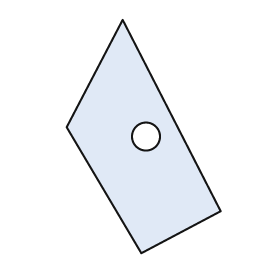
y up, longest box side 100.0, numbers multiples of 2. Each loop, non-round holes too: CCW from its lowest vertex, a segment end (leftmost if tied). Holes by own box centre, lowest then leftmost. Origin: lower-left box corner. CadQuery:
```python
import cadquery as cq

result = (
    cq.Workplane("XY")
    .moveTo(32.0, 0.0)
    .lineTo(66.0, 18.0)
    .lineTo(24.0, 100.0)
    .lineTo(0.0, 54.0)
    .close()
    .moveTo(34.0, 50.0)
    .circle(6.0)
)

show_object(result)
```